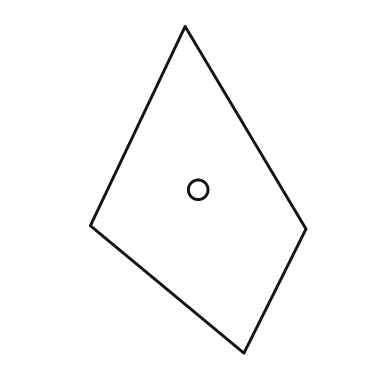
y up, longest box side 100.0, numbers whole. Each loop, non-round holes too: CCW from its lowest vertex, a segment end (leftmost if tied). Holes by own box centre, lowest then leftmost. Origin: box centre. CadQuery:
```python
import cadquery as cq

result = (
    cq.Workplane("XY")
    .moveTo(14.0, -50.0)
    .lineTo(33.0, -12.0)
    .lineTo(-4.0, 50.0)
    .lineTo(-33.0, -11.0)
    .close()
    .moveTo(0.0, 0.0)
    .circle(3.0)
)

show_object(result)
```